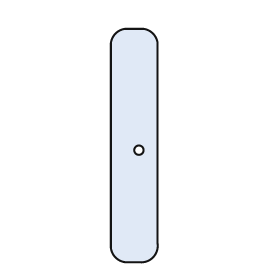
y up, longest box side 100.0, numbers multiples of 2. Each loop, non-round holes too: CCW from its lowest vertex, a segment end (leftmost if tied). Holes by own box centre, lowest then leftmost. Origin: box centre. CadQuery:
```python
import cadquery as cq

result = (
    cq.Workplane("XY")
    .moveTo(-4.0, -50.0)
    .lineTo(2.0, -50.0)
    .threePointArc((8.0, -48.0), (10.0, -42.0))
    .lineTo(10.0, 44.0)
    .threePointArc((8.0, 48.0), (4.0, 50.0))
    .lineTo(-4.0, 50.0)
    .threePointArc((-8.0, 48.0), (-10.0, 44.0))
    .lineTo(-10.0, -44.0)
    .threePointArc((-8.0, -48.0), (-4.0, -50.0))
    .close()
    .moveTo(2.0, -2.0)
    .circle(2.0)
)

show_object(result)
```